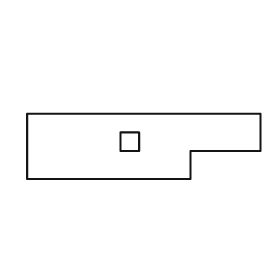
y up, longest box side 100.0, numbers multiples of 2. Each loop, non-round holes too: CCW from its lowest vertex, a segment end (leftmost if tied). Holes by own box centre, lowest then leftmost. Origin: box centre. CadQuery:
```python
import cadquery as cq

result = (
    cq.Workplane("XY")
    .moveTo(-50.0, -14.0)
    .lineTo(20.0, -14.0)
    .lineTo(20.0, -2.0)
    .lineTo(50.0, -2.0)
    .lineTo(50.0, 14.0)
    .lineTo(-50.0, 14.0)
    .close()
    .moveTo(-10.0, -2.0)
    .lineTo(-2.0, -2.0)
    .lineTo(-2.0, 6.0)
    .lineTo(-10.0, 6.0)
    .close()
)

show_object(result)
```